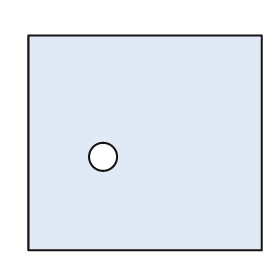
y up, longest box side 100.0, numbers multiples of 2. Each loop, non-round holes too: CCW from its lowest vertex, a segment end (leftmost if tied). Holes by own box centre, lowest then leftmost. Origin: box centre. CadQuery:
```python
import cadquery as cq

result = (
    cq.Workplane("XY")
    .moveTo(-50.0, -46.0)
    .lineTo(50.0, -46.0)
    .lineTo(50.0, 46.0)
    .lineTo(-50.0, 46.0)
    .close()
    .moveTo(-18.0, -6.0)
    .circle(6.0)
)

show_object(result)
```